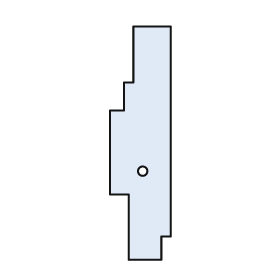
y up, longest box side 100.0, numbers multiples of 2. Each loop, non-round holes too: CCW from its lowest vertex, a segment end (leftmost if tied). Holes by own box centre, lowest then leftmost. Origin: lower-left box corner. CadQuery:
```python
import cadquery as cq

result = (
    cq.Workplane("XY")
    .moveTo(8.0, 0.0)
    .lineTo(22.0, 0.0)
    .lineTo(22.0, 10.0)
    .lineTo(26.0, 10.0)
    .lineTo(26.0, 100.0)
    .lineTo(10.0, 100.0)
    .lineTo(10.0, 76.0)
    .lineTo(6.0, 76.0)
    .lineTo(6.0, 64.0)
    .lineTo(0.0, 64.0)
    .lineTo(0.0, 28.0)
    .lineTo(8.0, 28.0)
    .close()
    .moveTo(14.0, 38.0)
    .circle(2.0)
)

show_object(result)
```